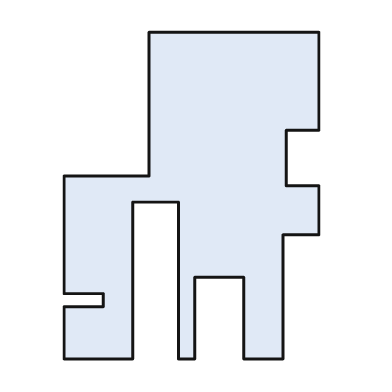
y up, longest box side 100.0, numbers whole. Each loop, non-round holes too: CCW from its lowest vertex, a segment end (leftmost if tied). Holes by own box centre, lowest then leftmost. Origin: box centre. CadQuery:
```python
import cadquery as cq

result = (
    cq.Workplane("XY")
    .moveTo(-39.0, -50.0)
    .lineTo(-18.0, -50.0)
    .lineTo(-18.0, -2.0)
    .lineTo(-4.0, -2.0)
    .lineTo(-4.0, -50.0)
    .lineTo(1.0, -50.0)
    .lineTo(1.0, -25.0)
    .lineTo(16.0, -25.0)
    .lineTo(16.0, -50.0)
    .lineTo(28.0, -50.0)
    .lineTo(28.0, -12.0)
    .lineTo(39.0, -12.0)
    .lineTo(39.0, 3.0)
    .lineTo(29.0, 3.0)
    .lineTo(29.0, 20.0)
    .lineTo(39.0, 20.0)
    .lineTo(39.0, 50.0)
    .lineTo(-13.0, 50.0)
    .lineTo(-13.0, 6.0)
    .lineTo(-39.0, 6.0)
    .lineTo(-39.0, -30.0)
    .lineTo(-27.0, -30.0)
    .lineTo(-27.0, -34.0)
    .lineTo(-39.0, -34.0)
    .close()
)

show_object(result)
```